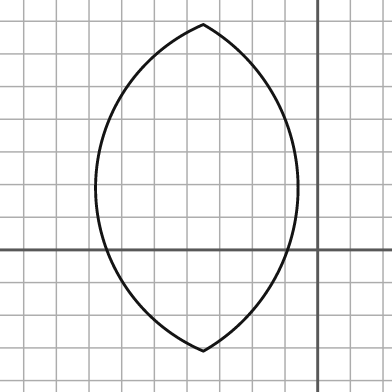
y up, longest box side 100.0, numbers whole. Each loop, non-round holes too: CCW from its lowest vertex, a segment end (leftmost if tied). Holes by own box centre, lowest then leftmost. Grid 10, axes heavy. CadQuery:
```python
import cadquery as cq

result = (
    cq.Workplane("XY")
    .moveTo(-35.0, -31.0)
    .threePointArc((-6.0, 19.0), (-35.0, 69.0))
    .threePointArc((-68.0, 19.0), (-35.0, -31.0))
    .close()
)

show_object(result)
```